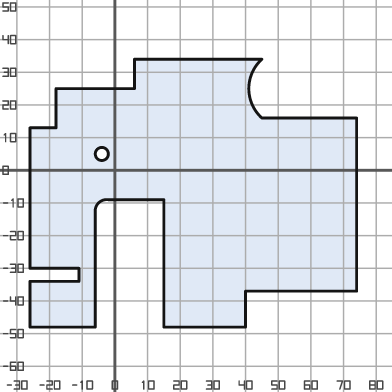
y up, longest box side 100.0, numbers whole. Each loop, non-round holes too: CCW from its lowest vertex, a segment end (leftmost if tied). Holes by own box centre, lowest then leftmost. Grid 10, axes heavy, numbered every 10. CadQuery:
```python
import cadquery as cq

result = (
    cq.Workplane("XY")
    .moveTo(-26.0, -48.0)
    .lineTo(-6.0, -48.0)
    .lineTo(-6.0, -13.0)
    .threePointArc((-5.0, -10.0), (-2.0, -9.0))
    .lineTo(15.0, -9.0)
    .lineTo(15.0, -48.0)
    .lineTo(40.0, -48.0)
    .lineTo(40.0, -37.0)
    .lineTo(74.0, -37.0)
    .lineTo(74.0, 16.0)
    .lineTo(45.0, 16.0)
    .threePointArc((41.0, 25.0), (45.0, 34.0))
    .lineTo(6.0, 34.0)
    .lineTo(6.0, 25.0)
    .lineTo(-18.0, 25.0)
    .lineTo(-18.0, 13.0)
    .lineTo(-26.0, 13.0)
    .lineTo(-26.0, -30.0)
    .lineTo(-11.0, -30.0)
    .lineTo(-11.0, -34.0)
    .lineTo(-26.0, -34.0)
    .close()
    .moveTo(-4.0, 5.0)
    .circle(2.0)
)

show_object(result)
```